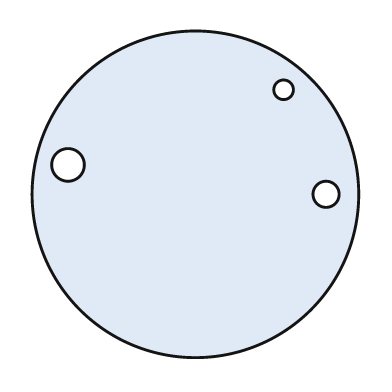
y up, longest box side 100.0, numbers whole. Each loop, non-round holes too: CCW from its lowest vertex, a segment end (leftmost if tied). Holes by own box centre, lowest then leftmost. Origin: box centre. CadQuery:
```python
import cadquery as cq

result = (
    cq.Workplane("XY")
    .moveTo(0.0, 0.0)
    .circle(50.0)
    .moveTo(40.0, 0.0)
    .circle(4.0)
    .moveTo(-39.0, 9.0)
    .circle(5.0)
    .moveTo(27.0, 32.0)
    .circle(3.0)
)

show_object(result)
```